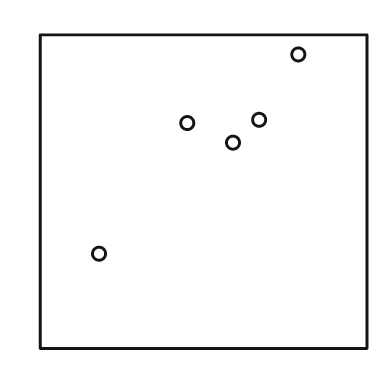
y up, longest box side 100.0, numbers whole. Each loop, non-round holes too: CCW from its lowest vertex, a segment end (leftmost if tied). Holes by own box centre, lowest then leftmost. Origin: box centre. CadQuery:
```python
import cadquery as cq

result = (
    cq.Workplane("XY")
    .moveTo(-50.0, -48.0)
    .lineTo(50.0, -48.0)
    .lineTo(50.0, 48.0)
    .lineTo(-50.0, 48.0)
    .close()
    .moveTo(-32.0, -19.0)
    .circle(2.0)
    .moveTo(9.0, 15.0)
    .circle(2.0)
    .moveTo(-5.0, 21.0)
    .circle(2.0)
    .moveTo(17.0, 22.0)
    .circle(2.0)
    .moveTo(29.0, 42.0)
    .circle(2.0)
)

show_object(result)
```